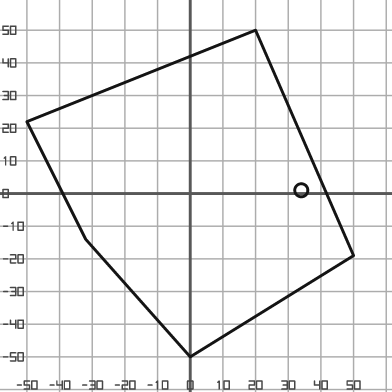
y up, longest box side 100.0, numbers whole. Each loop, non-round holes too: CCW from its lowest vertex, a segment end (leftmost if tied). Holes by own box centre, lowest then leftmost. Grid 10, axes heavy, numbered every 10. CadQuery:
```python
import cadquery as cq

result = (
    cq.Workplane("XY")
    .moveTo(0.0, -50.0)
    .lineTo(50.0, -19.0)
    .lineTo(20.0, 50.0)
    .lineTo(-50.0, 22.0)
    .lineTo(-32.0, -14.0)
    .close()
    .moveTo(34.0, 1.0)
    .circle(2.0)
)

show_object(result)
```